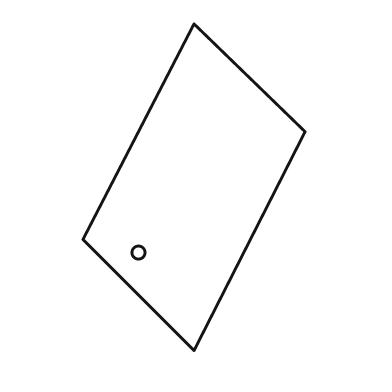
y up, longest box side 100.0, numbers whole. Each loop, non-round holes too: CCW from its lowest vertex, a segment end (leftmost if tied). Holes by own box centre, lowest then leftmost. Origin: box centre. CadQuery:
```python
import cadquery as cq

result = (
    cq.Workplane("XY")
    .moveTo(0.0, -50.0)
    .lineTo(34.0, 17.0)
    .lineTo(0.0, 50.0)
    .lineTo(-34.0, -16.0)
    .close()
    .moveTo(-17.0, -20.0)
    .circle(2.0)
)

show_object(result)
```